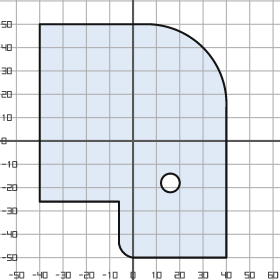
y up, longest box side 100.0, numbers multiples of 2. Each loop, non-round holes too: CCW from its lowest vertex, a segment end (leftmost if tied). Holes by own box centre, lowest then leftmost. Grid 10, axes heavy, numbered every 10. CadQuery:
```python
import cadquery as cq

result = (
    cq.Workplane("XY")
    .moveTo(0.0, -50.0)
    .lineTo(40.0, -50.0)
    .lineTo(40.0, 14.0)
    .threePointArc((30.0, 40.0), (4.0, 50.0))
    .lineTo(-40.0, 50.0)
    .lineTo(-40.0, -26.0)
    .lineTo(-6.0, -26.0)
    .lineTo(-6.0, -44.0)
    .threePointArc((-4.0, -48.0), (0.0, -50.0))
    .close()
    .moveTo(16.0, -18.0)
    .circle(4.0)
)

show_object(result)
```